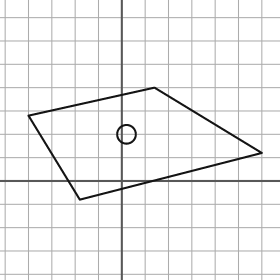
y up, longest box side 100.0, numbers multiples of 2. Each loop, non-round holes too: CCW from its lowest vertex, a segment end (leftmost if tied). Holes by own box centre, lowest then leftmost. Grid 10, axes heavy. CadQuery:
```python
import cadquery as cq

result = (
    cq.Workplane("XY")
    .moveTo(-18.0, -8.0)
    .lineTo(60.0, 12.0)
    .lineTo(14.0, 40.0)
    .lineTo(-40.0, 28.0)
    .close()
    .moveTo(2.0, 20.0)
    .circle(4.0)
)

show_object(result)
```